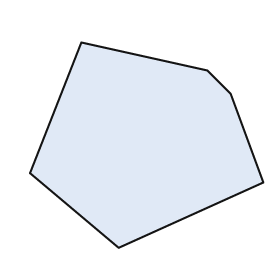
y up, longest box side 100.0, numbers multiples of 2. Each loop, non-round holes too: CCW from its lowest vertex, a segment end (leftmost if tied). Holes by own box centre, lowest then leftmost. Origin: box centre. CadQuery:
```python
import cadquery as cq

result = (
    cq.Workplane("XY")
    .moveTo(-12.0, -44.0)
    .lineTo(50.0, -16.0)
    .lineTo(36.0, 22.0)
    .lineTo(26.0, 32.0)
    .lineTo(-28.0, 44.0)
    .lineTo(-50.0, -12.0)
    .close()
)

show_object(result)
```